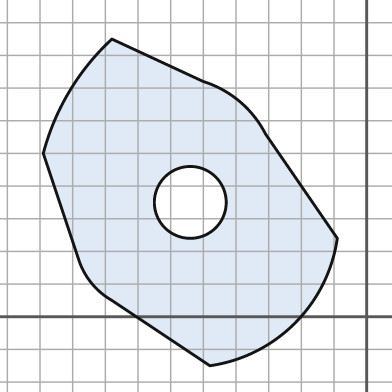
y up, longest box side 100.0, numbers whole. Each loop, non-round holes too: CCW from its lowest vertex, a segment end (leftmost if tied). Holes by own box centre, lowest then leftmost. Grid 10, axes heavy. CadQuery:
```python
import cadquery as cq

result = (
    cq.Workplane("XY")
    .moveTo(-48.0, -15.0)
    .threePointArc((-22.0, -2.0), (-9.0, 24.0))
    .lineTo(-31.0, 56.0)
    .threePointArc((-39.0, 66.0), (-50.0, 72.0))
    .lineTo(-78.0, 85.0)
    .threePointArc((-91.0, 69.0), (-99.0, 50.0))
    .lineTo(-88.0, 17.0)
    .threePointArc((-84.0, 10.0), (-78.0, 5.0))
    .close()
    .moveTo(-54.0, 35.0)
    .circle(11.0)
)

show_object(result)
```